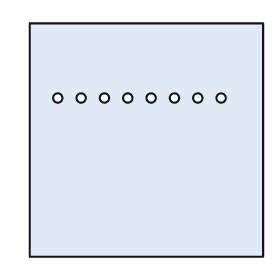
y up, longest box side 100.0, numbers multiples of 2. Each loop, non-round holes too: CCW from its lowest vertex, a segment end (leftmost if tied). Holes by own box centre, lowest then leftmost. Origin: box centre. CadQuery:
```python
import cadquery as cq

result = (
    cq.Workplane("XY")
    .moveTo(-50.0, -50.0)
    .lineTo(50.0, -50.0)
    .lineTo(50.0, 50.0)
    .lineTo(-50.0, 50.0)
    .close()
    .moveTo(-38.0, 18.0)
    .circle(2.0)
    .moveTo(-28.0, 18.0)
    .circle(2.0)
    .moveTo(-18.0, 18.0)
    .circle(2.0)
    .moveTo(-8.0, 18.0)
    .circle(2.0)
    .moveTo(2.0, 18.0)
    .circle(2.0)
    .moveTo(12.0, 18.0)
    .circle(2.0)
    .moveTo(22.0, 18.0)
    .circle(2.0)
    .moveTo(32.0, 18.0)
    .circle(2.0)
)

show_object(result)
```